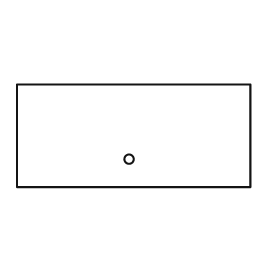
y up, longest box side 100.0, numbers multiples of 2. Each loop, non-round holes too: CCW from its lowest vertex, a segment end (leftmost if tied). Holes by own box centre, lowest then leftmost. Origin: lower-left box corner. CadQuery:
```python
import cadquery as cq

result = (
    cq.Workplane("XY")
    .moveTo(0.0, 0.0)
    .lineTo(100.0, 0.0)
    .lineTo(100.0, 44.0)
    .lineTo(0.0, 44.0)
    .close()
    .moveTo(48.0, 12.0)
    .circle(2.0)
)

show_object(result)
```